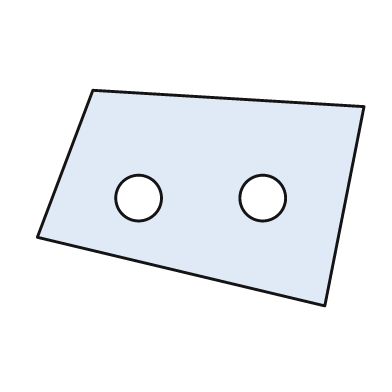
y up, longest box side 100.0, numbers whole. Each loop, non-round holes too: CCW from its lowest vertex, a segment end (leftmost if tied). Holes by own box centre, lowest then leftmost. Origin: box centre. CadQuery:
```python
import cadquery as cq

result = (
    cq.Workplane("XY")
    .moveTo(38.0, -33.0)
    .lineTo(50.0, 28.0)
    .lineTo(-33.0, 33.0)
    .lineTo(-50.0, -12.0)
    .close()
    .moveTo(-19.0, 0.0)
    .circle(7.0)
    .moveTo(19.0, 0.0)
    .circle(7.0)
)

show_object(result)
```